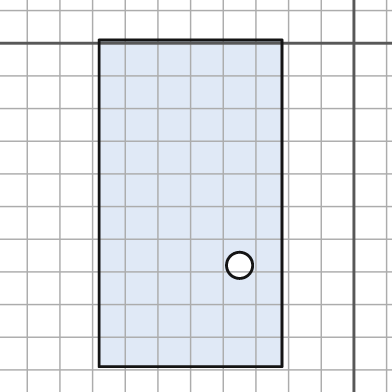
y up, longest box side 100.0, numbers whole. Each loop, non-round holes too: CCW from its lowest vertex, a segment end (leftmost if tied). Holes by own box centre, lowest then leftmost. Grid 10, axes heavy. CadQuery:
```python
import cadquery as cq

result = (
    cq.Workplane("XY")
    .moveTo(-78.0, -99.0)
    .lineTo(-22.0, -99.0)
    .lineTo(-22.0, 1.0)
    .lineTo(-78.0, 1.0)
    .close()
    .moveTo(-35.0, -68.0)
    .circle(4.0)
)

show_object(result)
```